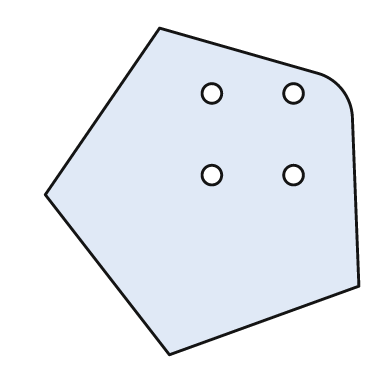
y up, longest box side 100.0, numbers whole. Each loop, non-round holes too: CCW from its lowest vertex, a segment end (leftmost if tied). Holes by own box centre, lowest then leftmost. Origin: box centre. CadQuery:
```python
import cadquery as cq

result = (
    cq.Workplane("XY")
    .moveTo(-10.0, -50.0)
    .lineTo(48.0, -29.0)
    .lineTo(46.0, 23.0)
    .threePointArc((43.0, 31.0), (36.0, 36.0))
    .lineTo(-13.0, 50.0)
    .lineTo(-48.0, -1.0)
    .close()
    .moveTo(3.0, 5.0)
    .circle(3.0)
    .moveTo(28.0, 5.0)
    .circle(3.0)
    .moveTo(3.0, 30.0)
    .circle(3.0)
    .moveTo(28.0, 30.0)
    .circle(3.0)
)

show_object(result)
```